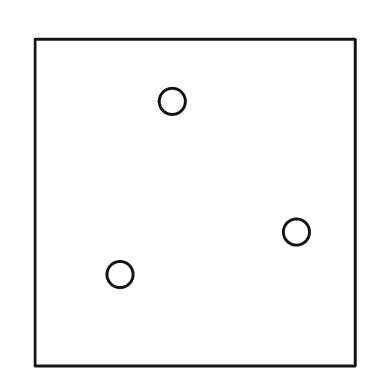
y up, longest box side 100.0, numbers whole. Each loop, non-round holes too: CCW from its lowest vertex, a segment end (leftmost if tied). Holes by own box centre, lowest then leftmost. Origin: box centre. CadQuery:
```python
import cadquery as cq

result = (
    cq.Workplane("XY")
    .moveTo(-49.0, -50.0)
    .lineTo(49.0, -50.0)
    .lineTo(49.0, 50.0)
    .lineTo(-49.0, 50.0)
    .close()
    .moveTo(-23.0, -22.0)
    .circle(4.0)
    .moveTo(31.0, -9.0)
    .circle(4.0)
    .moveTo(-7.0, 31.0)
    .circle(4.0)
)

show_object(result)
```